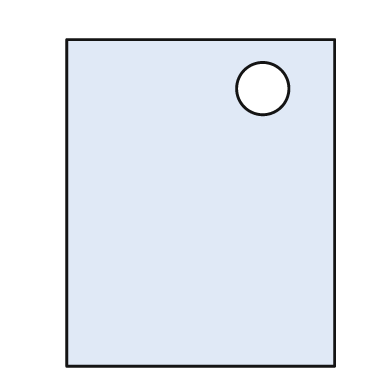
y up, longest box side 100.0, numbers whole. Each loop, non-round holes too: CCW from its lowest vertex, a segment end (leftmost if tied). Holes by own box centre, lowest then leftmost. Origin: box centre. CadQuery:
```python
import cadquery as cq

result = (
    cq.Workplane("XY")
    .moveTo(-41.0, -50.0)
    .lineTo(41.0, -50.0)
    .lineTo(41.0, 50.0)
    .lineTo(-41.0, 50.0)
    .close()
    .moveTo(19.0, 35.0)
    .circle(8.0)
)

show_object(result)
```